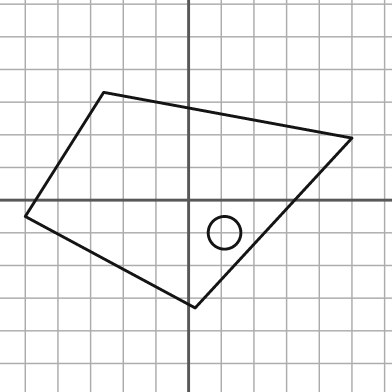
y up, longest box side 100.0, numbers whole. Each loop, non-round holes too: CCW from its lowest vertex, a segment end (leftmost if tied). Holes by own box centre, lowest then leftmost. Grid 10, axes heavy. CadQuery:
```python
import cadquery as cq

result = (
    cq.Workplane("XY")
    .moveTo(2.0, -33.0)
    .lineTo(50.0, 19.0)
    .lineTo(-26.0, 33.0)
    .lineTo(-50.0, -5.0)
    .close()
    .moveTo(11.0, -10.0)
    .circle(5.0)
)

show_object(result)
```